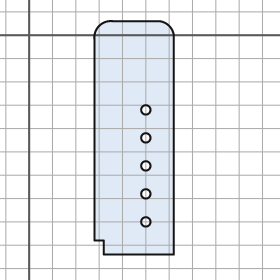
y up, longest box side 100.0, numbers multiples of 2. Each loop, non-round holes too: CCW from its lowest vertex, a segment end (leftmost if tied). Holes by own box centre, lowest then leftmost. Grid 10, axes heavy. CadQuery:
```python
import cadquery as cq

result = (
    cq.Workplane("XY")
    .moveTo(32.0, -94.0)
    .lineTo(62.0, -94.0)
    .lineTo(62.0, 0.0)
    .threePointArc((60.0, 4.0), (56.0, 6.0))
    .lineTo(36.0, 6.0)
    .threePointArc((30.0, 4.0), (28.0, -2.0))
    .lineTo(28.0, -88.0)
    .lineTo(32.0, -88.0)
    .close()
    .moveTo(50.0, -80.0)
    .circle(2.0)
    .moveTo(50.0, -68.0)
    .circle(2.0)
    .moveTo(50.0, -56.0)
    .circle(2.0)
    .moveTo(50.0, -44.0)
    .circle(2.0)
    .moveTo(50.0, -32.0)
    .circle(2.0)
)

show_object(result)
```